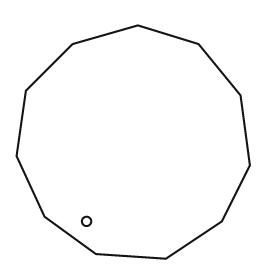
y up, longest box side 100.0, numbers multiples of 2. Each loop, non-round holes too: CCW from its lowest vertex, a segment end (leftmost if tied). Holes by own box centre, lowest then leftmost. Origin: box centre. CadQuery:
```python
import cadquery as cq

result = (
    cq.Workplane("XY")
    .moveTo(14.0, -50.0)
    .lineTo(38.0, -34.0)
    .lineTo(50.0, -10.0)
    .lineTo(46.0, 20.0)
    .lineTo(28.0, 42.0)
    .lineTo(2.0, 50.0)
    .lineTo(-26.0, 42.0)
    .lineTo(-46.0, 22.0)
    .lineTo(-50.0, -6.0)
    .lineTo(-38.0, -32.0)
    .lineTo(-16.0, -48.0)
    .close()
    .moveTo(-20.0, -34.0)
    .circle(2.0)
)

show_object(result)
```